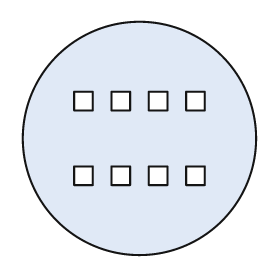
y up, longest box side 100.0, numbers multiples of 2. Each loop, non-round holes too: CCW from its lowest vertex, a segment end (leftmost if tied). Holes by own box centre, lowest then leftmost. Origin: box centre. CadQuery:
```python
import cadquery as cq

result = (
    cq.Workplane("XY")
    .moveTo(0.0, 0.0)
    .circle(50.0)
    .moveTo(-28.0, -20.0)
    .lineTo(-20.0, -20.0)
    .lineTo(-20.0, -12.0)
    .lineTo(-28.0, -12.0)
    .close()
    .moveTo(-12.0, -20.0)
    .lineTo(-4.0, -20.0)
    .lineTo(-4.0, -12.0)
    .lineTo(-12.0, -12.0)
    .close()
    .moveTo(4.0, -20.0)
    .lineTo(12.0, -20.0)
    .lineTo(12.0, -12.0)
    .lineTo(4.0, -12.0)
    .close()
    .moveTo(20.0, -20.0)
    .lineTo(28.0, -20.0)
    .lineTo(28.0, -12.0)
    .lineTo(20.0, -12.0)
    .close()
    .moveTo(-28.0, 12.0)
    .lineTo(-20.0, 12.0)
    .lineTo(-20.0, 20.0)
    .lineTo(-28.0, 20.0)
    .close()
    .moveTo(-12.0, 12.0)
    .lineTo(-4.0, 12.0)
    .lineTo(-4.0, 20.0)
    .lineTo(-12.0, 20.0)
    .close()
    .moveTo(4.0, 12.0)
    .lineTo(12.0, 12.0)
    .lineTo(12.0, 20.0)
    .lineTo(4.0, 20.0)
    .close()
    .moveTo(20.0, 12.0)
    .lineTo(28.0, 12.0)
    .lineTo(28.0, 20.0)
    .lineTo(20.0, 20.0)
    .close()
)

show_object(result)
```